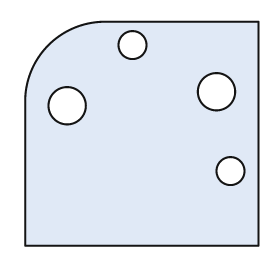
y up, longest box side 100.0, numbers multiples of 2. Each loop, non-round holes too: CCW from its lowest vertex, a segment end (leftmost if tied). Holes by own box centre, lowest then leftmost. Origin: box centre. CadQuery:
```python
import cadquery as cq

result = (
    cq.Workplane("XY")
    .moveTo(-50.0, -48.0)
    .lineTo(50.0, -48.0)
    .lineTo(50.0, 48.0)
    .lineTo(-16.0, 48.0)
    .threePointArc((-40.0, 38.0), (-50.0, 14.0))
    .close()
    .moveTo(38.0, -16.0)
    .circle(6.0)
    .moveTo(-32.0, 12.0)
    .circle(8.0)
    .moveTo(32.0, 18.0)
    .circle(8.0)
    .moveTo(-4.0, 38.0)
    .circle(6.0)
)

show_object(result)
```